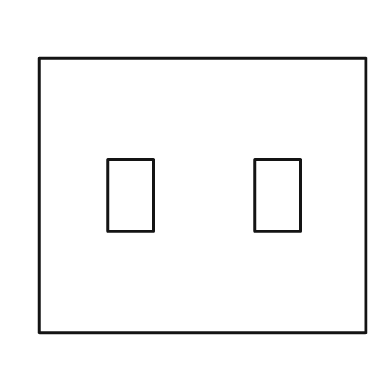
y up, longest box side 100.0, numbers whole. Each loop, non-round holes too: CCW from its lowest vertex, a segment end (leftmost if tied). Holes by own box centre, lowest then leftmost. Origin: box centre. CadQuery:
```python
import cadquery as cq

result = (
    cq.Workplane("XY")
    .moveTo(-50.0, -42.0)
    .lineTo(50.0, -42.0)
    .lineTo(50.0, 42.0)
    .lineTo(-50.0, 42.0)
    .close()
    .moveTo(-29.0, -11.0)
    .lineTo(-15.0, -11.0)
    .lineTo(-15.0, 11.0)
    .lineTo(-29.0, 11.0)
    .close()
    .moveTo(16.0, -11.0)
    .lineTo(30.0, -11.0)
    .lineTo(30.0, 11.0)
    .lineTo(16.0, 11.0)
    .close()
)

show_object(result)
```